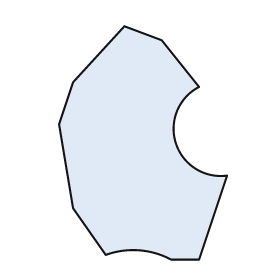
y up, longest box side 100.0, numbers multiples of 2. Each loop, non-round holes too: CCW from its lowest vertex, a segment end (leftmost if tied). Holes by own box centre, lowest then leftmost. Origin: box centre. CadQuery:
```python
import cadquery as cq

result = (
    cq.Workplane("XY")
    .moveTo(12.0, -50.0)
    .lineTo(24.0, -50.0)
    .lineTo(36.0, -14.0)
    .threePointArc((14.0, 0.0), (24.0, 24.0))
    .lineTo(8.0, 44.0)
    .lineTo(-8.0, 50.0)
    .lineTo(-30.0, 26.0)
    .lineTo(-36.0, 8.0)
    .lineTo(-30.0, -28.0)
    .lineTo(-16.0, -48.0)
    .threePointArc((-2.0, -46.0), (12.0, -50.0))
    .close()
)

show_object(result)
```